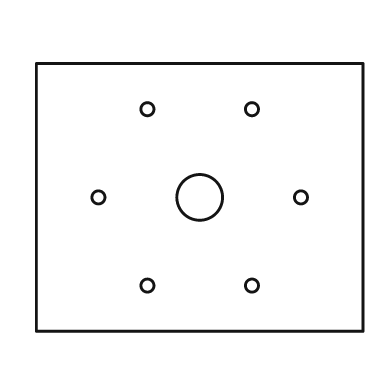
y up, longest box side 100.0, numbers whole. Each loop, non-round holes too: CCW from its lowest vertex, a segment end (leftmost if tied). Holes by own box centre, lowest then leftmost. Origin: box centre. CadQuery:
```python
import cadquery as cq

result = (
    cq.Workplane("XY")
    .moveTo(-50.0, -41.0)
    .lineTo(50.0, -41.0)
    .lineTo(50.0, 41.0)
    .lineTo(-50.0, 41.0)
    .close()
    .moveTo(-16.0, -27.0)
    .circle(2.0)
    .moveTo(16.0, -27.0)
    .circle(2.0)
    .moveTo(-31.0, 0.0)
    .circle(2.0)
    .moveTo(0.0, 0.0)
    .circle(7.0)
    .moveTo(31.0, 0.0)
    .circle(2.0)
    .moveTo(-16.0, 27.0)
    .circle(2.0)
    .moveTo(16.0, 27.0)
    .circle(2.0)
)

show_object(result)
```